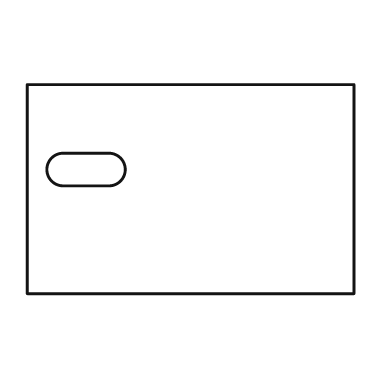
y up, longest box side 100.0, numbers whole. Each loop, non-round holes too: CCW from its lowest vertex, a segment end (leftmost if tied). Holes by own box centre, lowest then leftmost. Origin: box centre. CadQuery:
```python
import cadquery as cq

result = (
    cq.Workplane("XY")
    .moveTo(-50.0, -32.0)
    .lineTo(50.0, -32.0)
    .lineTo(50.0, 32.0)
    .lineTo(-50.0, 32.0)
    .close()
    .moveTo(-39.0, 1.0)
    .lineTo(-25.0, 1.0)
    .threePointArc((-20.0, 6.0), (-25.0, 11.0))
    .lineTo(-39.0, 11.0)
    .threePointArc((-44.0, 6.0), (-39.0, 1.0))
    .close()
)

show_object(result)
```